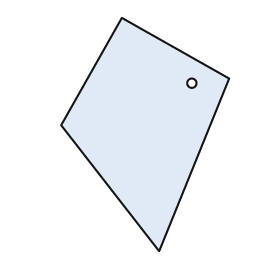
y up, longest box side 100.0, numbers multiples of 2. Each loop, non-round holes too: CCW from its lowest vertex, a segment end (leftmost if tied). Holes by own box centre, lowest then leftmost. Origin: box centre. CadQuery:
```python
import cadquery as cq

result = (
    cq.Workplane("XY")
    .moveTo(6.0, -50.0)
    .lineTo(36.0, 24.0)
    .lineTo(-10.0, 50.0)
    .lineTo(-36.0, 4.0)
    .close()
    .moveTo(20.0, 22.0)
    .circle(2.0)
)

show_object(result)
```